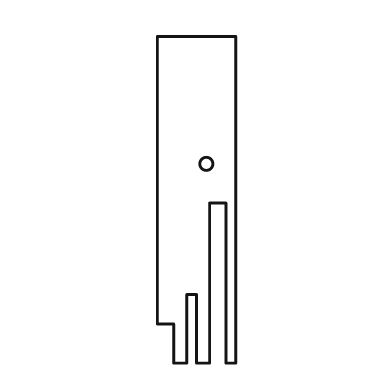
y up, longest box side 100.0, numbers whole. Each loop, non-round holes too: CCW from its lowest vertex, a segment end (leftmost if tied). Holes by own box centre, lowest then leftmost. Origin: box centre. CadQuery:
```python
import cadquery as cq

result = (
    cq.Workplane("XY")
    .moveTo(-7.0, -50.0)
    .lineTo(-3.0, -50.0)
    .lineTo(-3.0, -29.0)
    .lineTo(0.0, -29.0)
    .lineTo(0.0, -50.0)
    .lineTo(4.0, -50.0)
    .lineTo(4.0, -1.0)
    .lineTo(9.0, -1.0)
    .lineTo(9.0, -50.0)
    .lineTo(12.0, -50.0)
    .lineTo(12.0, 50.0)
    .lineTo(-12.0, 50.0)
    .lineTo(-12.0, -38.0)
    .lineTo(-7.0, -38.0)
    .close()
    .moveTo(3.0, 11.0)
    .circle(2.0)
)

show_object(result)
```